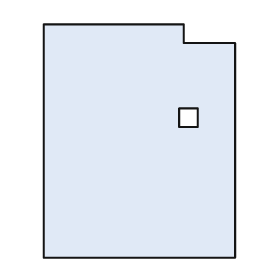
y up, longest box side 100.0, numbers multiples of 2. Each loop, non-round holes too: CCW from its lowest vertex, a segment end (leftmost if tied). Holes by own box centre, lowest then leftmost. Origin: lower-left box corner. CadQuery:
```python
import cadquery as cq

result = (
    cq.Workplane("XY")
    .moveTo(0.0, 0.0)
    .lineTo(82.0, 0.0)
    .lineTo(82.0, 92.0)
    .lineTo(60.0, 92.0)
    .lineTo(60.0, 100.0)
    .lineTo(0.0, 100.0)
    .close()
    .moveTo(58.0, 56.0)
    .lineTo(66.0, 56.0)
    .lineTo(66.0, 64.0)
    .lineTo(58.0, 64.0)
    .close()
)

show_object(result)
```